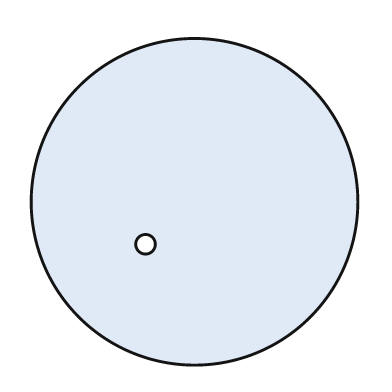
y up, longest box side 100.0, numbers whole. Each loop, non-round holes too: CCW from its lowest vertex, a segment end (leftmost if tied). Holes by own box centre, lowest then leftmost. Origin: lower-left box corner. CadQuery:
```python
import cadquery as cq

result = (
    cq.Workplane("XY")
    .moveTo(50.0, 50.0)
    .circle(50.0)
    .moveTo(35.0, 37.0)
    .circle(3.0)
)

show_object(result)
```